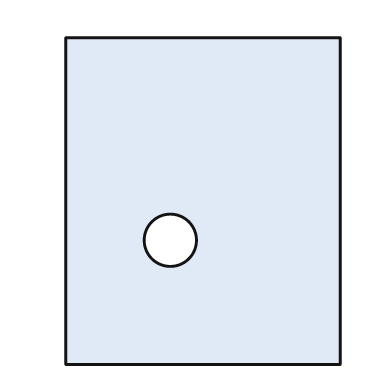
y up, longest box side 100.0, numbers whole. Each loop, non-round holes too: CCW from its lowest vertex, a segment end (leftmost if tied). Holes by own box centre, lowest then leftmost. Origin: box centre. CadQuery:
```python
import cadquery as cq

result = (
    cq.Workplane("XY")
    .moveTo(-42.0, -50.0)
    .lineTo(42.0, -50.0)
    .lineTo(42.0, 50.0)
    .lineTo(-42.0, 50.0)
    .close()
    .moveTo(-10.0, -12.0)
    .circle(8.0)
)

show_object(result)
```